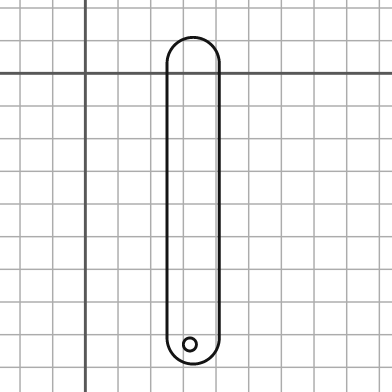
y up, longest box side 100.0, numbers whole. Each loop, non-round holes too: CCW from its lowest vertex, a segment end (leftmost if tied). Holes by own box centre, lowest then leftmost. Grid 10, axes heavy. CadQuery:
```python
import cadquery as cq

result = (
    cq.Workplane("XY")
    .moveTo(25.0, -81.0)
    .threePointArc((33.0, -89.0), (41.0, -81.0))
    .lineTo(41.0, 3.0)
    .threePointArc((33.0, 11.0), (25.0, 3.0))
    .close()
    .moveTo(32.0, -83.0)
    .circle(2.0)
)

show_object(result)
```